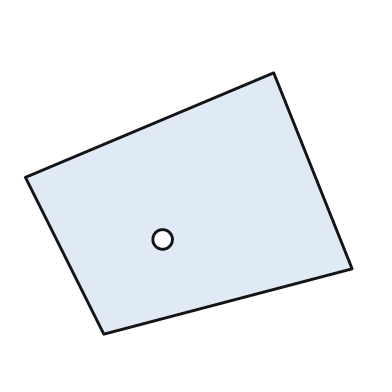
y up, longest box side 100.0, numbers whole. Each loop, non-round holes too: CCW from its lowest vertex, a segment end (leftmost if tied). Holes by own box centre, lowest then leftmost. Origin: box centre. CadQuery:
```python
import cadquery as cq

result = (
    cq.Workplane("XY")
    .moveTo(-26.0, -40.0)
    .lineTo(50.0, -20.0)
    .lineTo(26.0, 40.0)
    .lineTo(-50.0, 8.0)
    .close()
    .moveTo(-8.0, -11.0)
    .circle(3.0)
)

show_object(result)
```